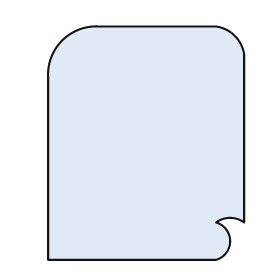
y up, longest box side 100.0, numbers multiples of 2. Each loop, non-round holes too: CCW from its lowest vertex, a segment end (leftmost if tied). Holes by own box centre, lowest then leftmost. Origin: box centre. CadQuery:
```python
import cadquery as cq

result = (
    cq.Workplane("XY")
    .moveTo(-42.0, -50.0)
    .lineTo(30.0, -50.0)
    .threePointArc((36.0, -42.0), (30.0, -34.0))
    .threePointArc((36.0, -32.0), (42.0, -34.0))
    .lineTo(42.0, 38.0)
    .threePointArc((38.0, 46.0), (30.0, 50.0))
    .lineTo(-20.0, 50.0)
    .threePointArc((-36.0, 44.0), (-42.0, 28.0))
    .close()
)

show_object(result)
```